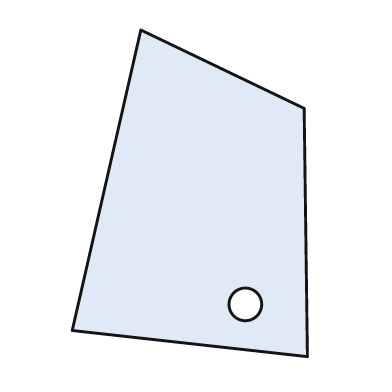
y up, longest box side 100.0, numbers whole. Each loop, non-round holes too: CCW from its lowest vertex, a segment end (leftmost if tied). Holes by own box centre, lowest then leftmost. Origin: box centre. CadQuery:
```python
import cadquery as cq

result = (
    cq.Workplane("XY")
    .moveTo(36.0, -50.0)
    .lineTo(35.0, 26.0)
    .lineTo(-15.0, 50.0)
    .lineTo(-36.0, -42.0)
    .close()
    .moveTo(17.0, -34.0)
    .circle(5.0)
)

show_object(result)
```